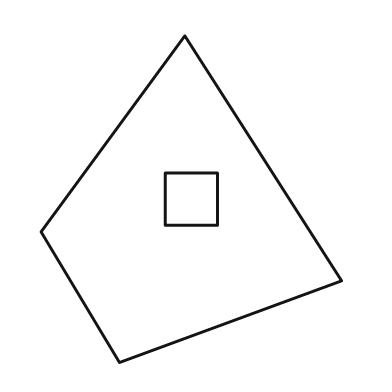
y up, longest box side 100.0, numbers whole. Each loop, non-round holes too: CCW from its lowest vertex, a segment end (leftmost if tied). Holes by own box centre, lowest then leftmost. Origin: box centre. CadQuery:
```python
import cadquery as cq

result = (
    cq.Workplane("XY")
    .moveTo(-22.0, -50.0)
    .lineTo(46.0, -25.0)
    .lineTo(-2.0, 50.0)
    .lineTo(-46.0, -10.0)
    .close()
    .moveTo(-8.0, -8.0)
    .lineTo(8.0, -8.0)
    .lineTo(8.0, 8.0)
    .lineTo(-8.0, 8.0)
    .close()
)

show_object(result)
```